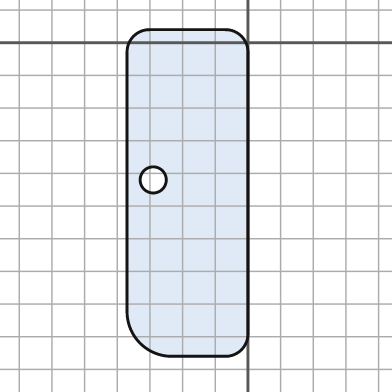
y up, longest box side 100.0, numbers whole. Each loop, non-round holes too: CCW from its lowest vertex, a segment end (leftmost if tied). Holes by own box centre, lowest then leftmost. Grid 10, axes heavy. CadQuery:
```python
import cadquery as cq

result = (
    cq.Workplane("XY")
    .moveTo(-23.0, -96.0)
    .lineTo(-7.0, -96.0)
    .threePointArc((-2.0, -94.0), (0.0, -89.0))
    .lineTo(0.0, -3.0)
    .threePointArc((-2.0, 2.0), (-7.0, 4.0))
    .lineTo(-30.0, 4.0)
    .threePointArc((-35.0, 2.0), (-37.0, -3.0))
    .lineTo(-37.0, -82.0)
    .threePointArc((-33.0, -92.0), (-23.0, -96.0))
    .close()
    .moveTo(-29.0, -42.0)
    .circle(4.0)
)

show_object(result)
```